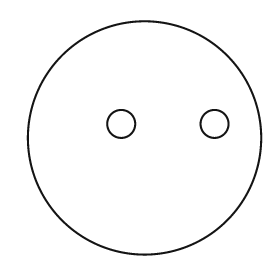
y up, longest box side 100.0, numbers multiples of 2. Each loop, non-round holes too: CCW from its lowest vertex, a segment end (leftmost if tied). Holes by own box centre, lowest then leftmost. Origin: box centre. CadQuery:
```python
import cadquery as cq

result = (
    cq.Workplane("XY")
    .moveTo(0.0, 0.0)
    .circle(50.0)
    .moveTo(-10.0, 6.0)
    .circle(6.0)
    .moveTo(30.0, 6.0)
    .circle(6.0)
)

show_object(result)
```